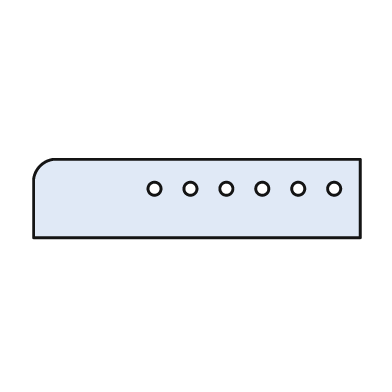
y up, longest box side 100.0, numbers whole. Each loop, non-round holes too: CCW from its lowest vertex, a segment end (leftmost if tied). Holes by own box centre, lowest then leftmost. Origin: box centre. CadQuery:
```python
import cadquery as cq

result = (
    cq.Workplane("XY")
    .moveTo(-50.0, -12.0)
    .lineTo(50.0, -12.0)
    .lineTo(50.0, 12.0)
    .lineTo(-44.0, 12.0)
    .threePointArc((-48.0, 10.0), (-50.0, 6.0))
    .close()
    .moveTo(-13.0, 3.0)
    .circle(2.0)
    .moveTo(-2.0, 3.0)
    .circle(2.0)
    .moveTo(9.0, 3.0)
    .circle(2.0)
    .moveTo(20.0, 3.0)
    .circle(2.0)
    .moveTo(31.0, 3.0)
    .circle(2.0)
    .moveTo(42.0, 3.0)
    .circle(2.0)
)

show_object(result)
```